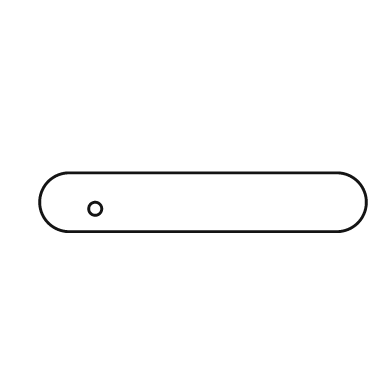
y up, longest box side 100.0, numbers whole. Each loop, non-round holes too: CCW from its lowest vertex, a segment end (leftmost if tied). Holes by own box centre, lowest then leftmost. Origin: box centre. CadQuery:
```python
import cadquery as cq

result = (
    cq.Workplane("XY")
    .moveTo(-41.0, -9.0)
    .lineTo(41.0, -9.0)
    .threePointArc((50.0, 0.0), (41.0, 9.0))
    .lineTo(-41.0, 9.0)
    .threePointArc((-50.0, 0.0), (-41.0, -9.0))
    .close()
    .moveTo(-33.0, -2.0)
    .circle(2.0)
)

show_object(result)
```